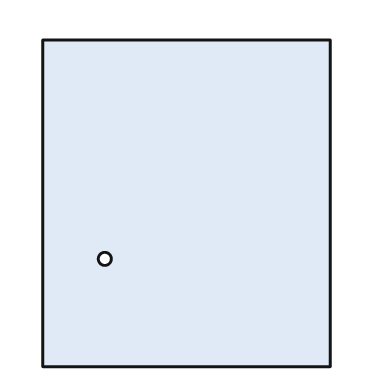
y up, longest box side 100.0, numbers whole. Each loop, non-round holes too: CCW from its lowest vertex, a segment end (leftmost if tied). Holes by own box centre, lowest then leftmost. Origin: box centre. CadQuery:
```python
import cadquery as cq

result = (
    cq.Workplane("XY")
    .moveTo(-44.0, -50.0)
    .lineTo(44.0, -50.0)
    .lineTo(44.0, 50.0)
    .lineTo(-44.0, 50.0)
    .close()
    .moveTo(-25.0, -17.0)
    .circle(2.0)
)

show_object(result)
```